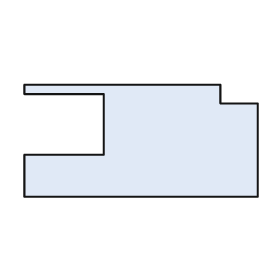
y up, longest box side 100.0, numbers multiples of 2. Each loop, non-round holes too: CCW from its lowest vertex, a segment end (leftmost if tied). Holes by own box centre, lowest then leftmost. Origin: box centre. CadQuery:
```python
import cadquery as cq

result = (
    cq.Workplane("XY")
    .moveTo(-50.0, -24.0)
    .lineTo(50.0, -24.0)
    .lineTo(50.0, 16.0)
    .lineTo(34.0, 16.0)
    .lineTo(34.0, 24.0)
    .lineTo(-50.0, 24.0)
    .lineTo(-50.0, 20.0)
    .lineTo(-16.0, 20.0)
    .lineTo(-16.0, -6.0)
    .lineTo(-50.0, -6.0)
    .close()
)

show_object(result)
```